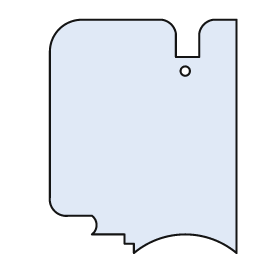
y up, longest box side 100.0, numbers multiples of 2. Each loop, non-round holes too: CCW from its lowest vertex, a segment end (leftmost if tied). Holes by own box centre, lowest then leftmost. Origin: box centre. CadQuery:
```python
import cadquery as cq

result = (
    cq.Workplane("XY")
    .moveTo(-4.0, -50.0)
    .threePointArc((18.0, -42.0), (40.0, -50.0))
    .lineTo(40.0, 50.0)
    .lineTo(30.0, 50.0)
    .threePointArc((26.0, 48.0), (24.0, 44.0))
    .lineTo(24.0, 34.0)
    .lineTo(14.0, 34.0)
    .lineTo(14.0, 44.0)
    .threePointArc((12.0, 48.0), (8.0, 50.0))
    .lineTo(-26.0, 50.0)
    .threePointArc((-36.0, 46.0), (-40.0, 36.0))
    .lineTo(-40.0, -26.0)
    .threePointArc((-38.0, -32.0), (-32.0, -34.0))
    .lineTo(-22.0, -34.0)
    .threePointArc((-20.0, -38.0), (-22.0, -42.0))
    .lineTo(-8.0, -42.0)
    .lineTo(-8.0, -46.0)
    .lineTo(-4.0, -46.0)
    .close()
    .moveTo(18.0, 28.0)
    .circle(2.0)
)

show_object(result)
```